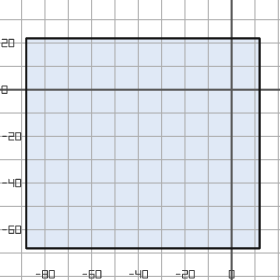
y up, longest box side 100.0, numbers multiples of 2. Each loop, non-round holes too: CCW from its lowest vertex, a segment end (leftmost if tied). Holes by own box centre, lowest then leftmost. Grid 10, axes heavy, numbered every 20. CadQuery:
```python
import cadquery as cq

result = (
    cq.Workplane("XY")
    .moveTo(-88.0, -68.0)
    .lineTo(12.0, -68.0)
    .lineTo(12.0, 22.0)
    .lineTo(-88.0, 22.0)
    .close()
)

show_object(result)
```